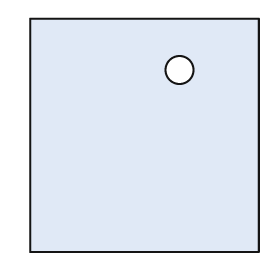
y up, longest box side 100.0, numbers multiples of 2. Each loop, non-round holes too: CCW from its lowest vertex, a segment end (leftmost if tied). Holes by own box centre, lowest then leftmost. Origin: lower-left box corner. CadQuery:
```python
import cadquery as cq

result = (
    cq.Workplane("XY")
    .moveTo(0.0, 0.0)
    .lineTo(98.0, 0.0)
    .lineTo(98.0, 100.0)
    .lineTo(0.0, 100.0)
    .close()
    .moveTo(64.0, 78.0)
    .circle(6.0)
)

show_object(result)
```